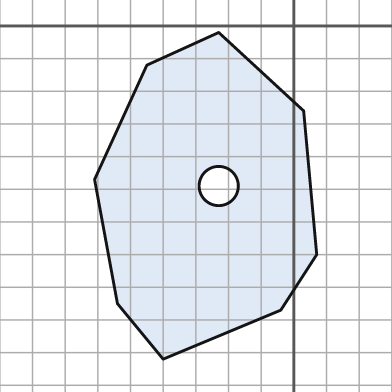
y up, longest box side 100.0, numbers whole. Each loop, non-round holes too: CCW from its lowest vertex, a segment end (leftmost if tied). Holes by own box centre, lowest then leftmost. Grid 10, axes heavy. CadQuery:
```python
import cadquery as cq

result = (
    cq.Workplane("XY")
    .moveTo(-40.0, -102.0)
    .lineTo(-4.0, -87.0)
    .lineTo(7.0, -70.0)
    .lineTo(3.0, -26.0)
    .lineTo(-23.0, -2.0)
    .lineTo(-45.0, -12.0)
    .lineTo(-61.0, -47.0)
    .lineTo(-54.0, -85.0)
    .close()
    .moveTo(-23.0, -49.0)
    .circle(6.0)
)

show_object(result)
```